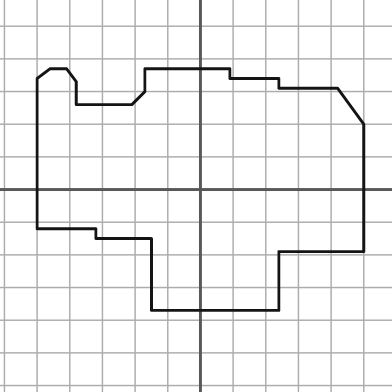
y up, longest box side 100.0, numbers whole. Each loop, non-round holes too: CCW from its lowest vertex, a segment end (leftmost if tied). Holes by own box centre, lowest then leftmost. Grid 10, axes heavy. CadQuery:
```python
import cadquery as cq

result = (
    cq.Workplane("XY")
    .moveTo(-15.0, -37.0)
    .lineTo(24.0, -37.0)
    .lineTo(24.0, -19.0)
    .lineTo(50.0, -19.0)
    .lineTo(50.0, 20.0)
    .lineTo(42.0, 31.0)
    .lineTo(24.0, 31.0)
    .lineTo(24.0, 34.0)
    .lineTo(9.0, 34.0)
    .lineTo(9.0, 37.0)
    .lineTo(-17.0, 37.0)
    .lineTo(-17.0, 30.0)
    .lineTo(-21.0, 26.0)
    .lineTo(-38.0, 26.0)
    .lineTo(-38.0, 33.0)
    .lineTo(-41.0, 37.0)
    .lineTo(-46.0, 37.0)
    .lineTo(-50.0, 34.0)
    .lineTo(-50.0, -12.0)
    .lineTo(-32.0, -12.0)
    .lineTo(-32.0, -15.0)
    .lineTo(-15.0, -15.0)
    .close()
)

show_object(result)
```